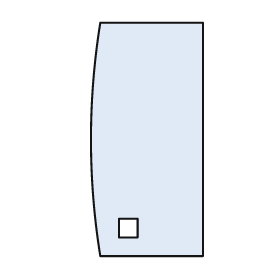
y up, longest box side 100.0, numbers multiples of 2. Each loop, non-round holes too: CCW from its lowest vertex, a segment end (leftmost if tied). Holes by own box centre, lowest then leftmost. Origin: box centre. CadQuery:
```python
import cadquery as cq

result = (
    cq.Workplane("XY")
    .moveTo(-20.0, -50.0)
    .lineTo(24.0, -50.0)
    .lineTo(24.0, 50.0)
    .lineTo(-20.0, 50.0)
    .threePointArc((-24.0, 0.0), (-20.0, -50.0))
    .close()
    .moveTo(-12.0, -42.0)
    .lineTo(-4.0, -42.0)
    .lineTo(-4.0, -34.0)
    .lineTo(-12.0, -34.0)
    .close()
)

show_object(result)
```